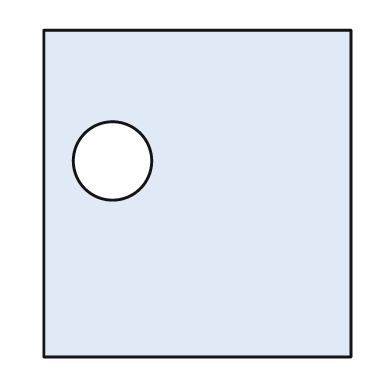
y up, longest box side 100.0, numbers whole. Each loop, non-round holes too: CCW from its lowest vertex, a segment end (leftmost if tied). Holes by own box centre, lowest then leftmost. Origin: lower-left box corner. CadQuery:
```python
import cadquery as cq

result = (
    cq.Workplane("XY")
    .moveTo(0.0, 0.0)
    .lineTo(94.0, 0.0)
    .lineTo(94.0, 100.0)
    .lineTo(0.0, 100.0)
    .close()
    .moveTo(21.0, 60.0)
    .circle(12.0)
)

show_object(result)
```